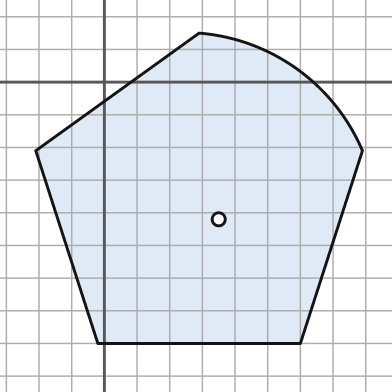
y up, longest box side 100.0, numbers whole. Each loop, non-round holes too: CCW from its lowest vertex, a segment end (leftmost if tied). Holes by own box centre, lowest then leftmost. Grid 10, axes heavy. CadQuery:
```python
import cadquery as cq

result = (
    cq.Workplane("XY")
    .moveTo(-2.0, -80.0)
    .lineTo(60.0, -80.0)
    .lineTo(79.0, -21.0)
    .threePointArc((59.0, 4.0), (29.0, 15.0))
    .lineTo(-21.0, -21.0)
    .close()
    .moveTo(35.0, -42.0)
    .circle(2.0)
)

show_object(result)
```